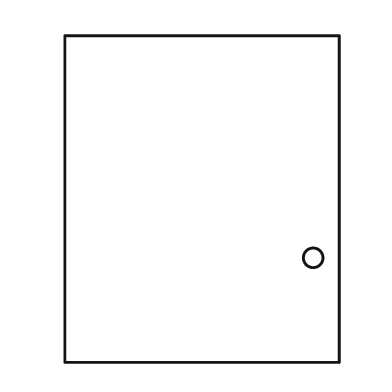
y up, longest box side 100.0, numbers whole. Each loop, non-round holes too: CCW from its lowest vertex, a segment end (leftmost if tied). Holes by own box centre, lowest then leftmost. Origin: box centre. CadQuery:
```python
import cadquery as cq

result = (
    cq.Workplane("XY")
    .moveTo(-42.0, -50.0)
    .lineTo(42.0, -50.0)
    .lineTo(42.0, 50.0)
    .lineTo(-42.0, 50.0)
    .close()
    .moveTo(34.0, -18.0)
    .circle(3.0)
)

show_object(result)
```